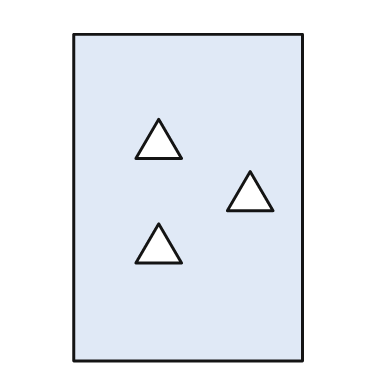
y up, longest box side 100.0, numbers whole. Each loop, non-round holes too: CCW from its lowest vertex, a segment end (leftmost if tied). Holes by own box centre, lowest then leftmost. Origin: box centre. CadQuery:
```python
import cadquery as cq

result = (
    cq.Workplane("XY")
    .moveTo(-35.0, -50.0)
    .lineTo(35.0, -50.0)
    .lineTo(35.0, 50.0)
    .lineTo(-35.0, 50.0)
    .close()
    .moveTo(-16.0, -20.0)
    .lineTo(-2.0, -20.0)
    .lineTo(-9.0, -8.0)
    .close()
    .moveTo(12.0, -4.0)
    .lineTo(26.0, -4.0)
    .lineTo(19.0, 8.0)
    .close()
    .moveTo(-16.0, 12.0)
    .lineTo(-2.0, 12.0)
    .lineTo(-9.0, 24.0)
    .close()
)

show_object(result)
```